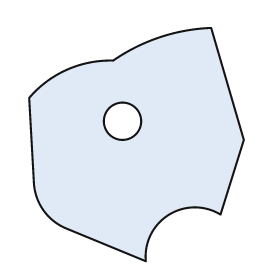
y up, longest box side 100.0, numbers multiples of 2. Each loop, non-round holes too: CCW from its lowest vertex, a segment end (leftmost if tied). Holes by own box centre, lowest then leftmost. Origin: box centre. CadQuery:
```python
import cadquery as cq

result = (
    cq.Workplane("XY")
    .moveTo(4.0, -50.0)
    .threePointArc((14.0, -30.0), (36.0, -30.0))
    .lineTo(46.0, 2.0)
    .lineTo(32.0, 50.0)
    .threePointArc((10.0, 46.0), (-10.0, 36.0))
    .threePointArc((-30.0, 32.0), (-46.0, 20.0))
    .lineTo(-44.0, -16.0)
    .threePointArc((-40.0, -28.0), (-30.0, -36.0))
    .close()
    .moveTo(-6.0, 10.0)
    .circle(8.0)
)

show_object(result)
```